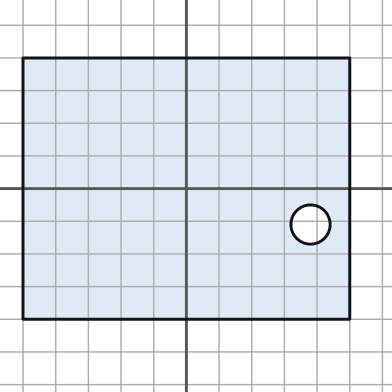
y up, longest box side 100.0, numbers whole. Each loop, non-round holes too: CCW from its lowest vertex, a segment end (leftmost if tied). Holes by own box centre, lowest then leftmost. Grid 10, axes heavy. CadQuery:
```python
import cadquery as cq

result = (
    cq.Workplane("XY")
    .moveTo(-50.0, -40.0)
    .lineTo(50.0, -40.0)
    .lineTo(50.0, 40.0)
    .lineTo(-50.0, 40.0)
    .close()
    .moveTo(38.0, -11.0)
    .circle(6.0)
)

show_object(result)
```